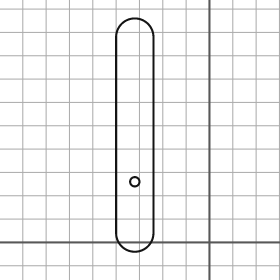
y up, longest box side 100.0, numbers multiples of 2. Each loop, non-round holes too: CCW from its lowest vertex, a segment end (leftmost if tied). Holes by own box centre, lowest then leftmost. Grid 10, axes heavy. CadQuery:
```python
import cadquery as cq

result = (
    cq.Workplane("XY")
    .moveTo(-40.0, 4.0)
    .threePointArc((-32.0, -4.0), (-24.0, 4.0))
    .lineTo(-24.0, 88.0)
    .threePointArc((-32.0, 96.0), (-40.0, 88.0))
    .close()
    .moveTo(-32.0, 26.0)
    .circle(2.0)
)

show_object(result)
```